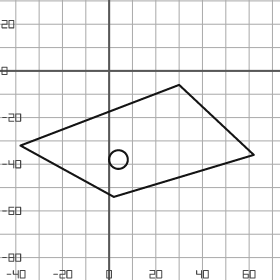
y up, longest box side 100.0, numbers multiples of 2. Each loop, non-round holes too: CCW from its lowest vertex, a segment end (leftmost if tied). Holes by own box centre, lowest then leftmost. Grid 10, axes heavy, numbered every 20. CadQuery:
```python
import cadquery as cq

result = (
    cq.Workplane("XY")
    .moveTo(2.0, -54.0)
    .lineTo(62.0, -36.0)
    .lineTo(30.0, -6.0)
    .lineTo(-38.0, -32.0)
    .close()
    .moveTo(4.0, -38.0)
    .circle(4.0)
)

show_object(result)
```